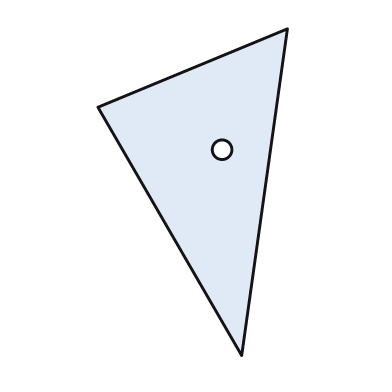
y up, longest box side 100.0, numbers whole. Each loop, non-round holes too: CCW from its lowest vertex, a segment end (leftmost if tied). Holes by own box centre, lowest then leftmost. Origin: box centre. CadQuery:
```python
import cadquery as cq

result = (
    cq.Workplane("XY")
    .moveTo(15.0, -50.0)
    .lineTo(29.0, 50.0)
    .lineTo(-29.0, 26.0)
    .close()
    .moveTo(9.0, 13.0)
    .circle(3.0)
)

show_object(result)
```